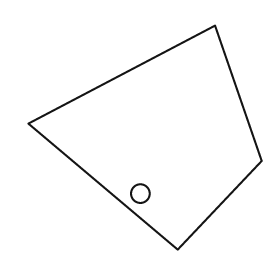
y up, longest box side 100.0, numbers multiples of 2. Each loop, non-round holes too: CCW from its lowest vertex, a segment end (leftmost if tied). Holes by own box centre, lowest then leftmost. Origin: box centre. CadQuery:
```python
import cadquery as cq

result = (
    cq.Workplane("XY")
    .moveTo(14.0, -48.0)
    .lineTo(50.0, -10.0)
    .lineTo(30.0, 48.0)
    .lineTo(-50.0, 6.0)
    .close()
    .moveTo(-2.0, -24.0)
    .circle(4.0)
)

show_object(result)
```